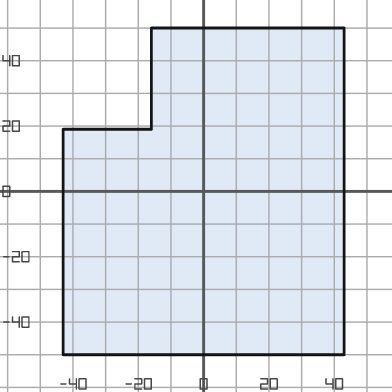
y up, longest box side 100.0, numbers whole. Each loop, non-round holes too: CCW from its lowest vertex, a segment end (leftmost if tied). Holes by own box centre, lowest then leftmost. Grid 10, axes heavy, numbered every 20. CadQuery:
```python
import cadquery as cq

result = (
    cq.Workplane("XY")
    .moveTo(-43.0, -50.0)
    .lineTo(43.0, -50.0)
    .lineTo(43.0, 50.0)
    .lineTo(-16.0, 50.0)
    .lineTo(-16.0, 19.0)
    .lineTo(-43.0, 19.0)
    .close()
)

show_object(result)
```